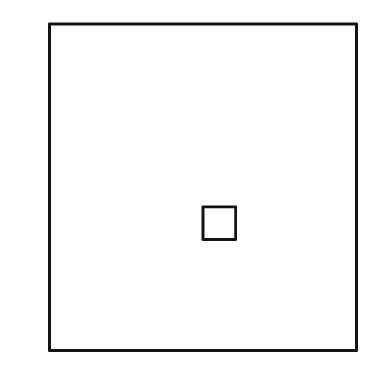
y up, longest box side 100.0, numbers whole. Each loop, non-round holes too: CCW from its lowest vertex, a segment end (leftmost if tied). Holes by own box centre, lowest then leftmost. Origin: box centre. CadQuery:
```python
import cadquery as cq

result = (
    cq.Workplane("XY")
    .moveTo(-47.0, -50.0)
    .lineTo(47.0, -50.0)
    .lineTo(47.0, 50.0)
    .lineTo(-47.0, 50.0)
    .close()
    .moveTo(0.0, -16.0)
    .lineTo(10.0, -16.0)
    .lineTo(10.0, -6.0)
    .lineTo(0.0, -6.0)
    .close()
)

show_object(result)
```